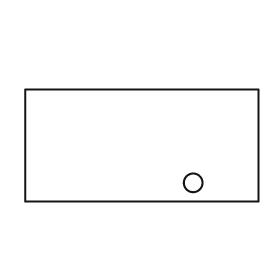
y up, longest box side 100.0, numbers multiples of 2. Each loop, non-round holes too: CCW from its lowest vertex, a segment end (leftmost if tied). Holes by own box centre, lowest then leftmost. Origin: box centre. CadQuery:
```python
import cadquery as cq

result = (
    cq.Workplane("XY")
    .moveTo(-50.0, -24.0)
    .lineTo(50.0, -24.0)
    .lineTo(50.0, 24.0)
    .lineTo(-50.0, 24.0)
    .close()
    .moveTo(22.0, -16.0)
    .circle(4.0)
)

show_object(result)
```